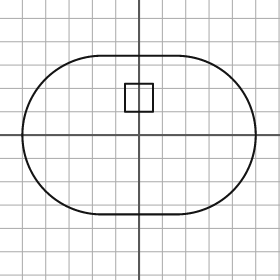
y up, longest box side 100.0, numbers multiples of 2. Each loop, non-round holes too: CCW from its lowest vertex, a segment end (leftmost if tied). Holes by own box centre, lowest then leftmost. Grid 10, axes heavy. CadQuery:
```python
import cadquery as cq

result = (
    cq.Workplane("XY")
    .moveTo(-16.0, -34.0)
    .lineTo(16.0, -34.0)
    .threePointArc((50.0, 0.0), (16.0, 34.0))
    .lineTo(-16.0, 34.0)
    .threePointArc((-50.0, 0.0), (-16.0, -34.0))
    .close()
    .moveTo(-6.0, 10.0)
    .lineTo(6.0, 10.0)
    .lineTo(6.0, 22.0)
    .lineTo(-6.0, 22.0)
    .close()
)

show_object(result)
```